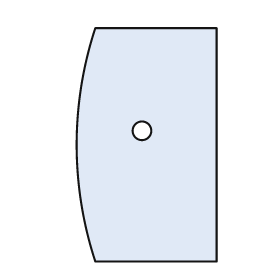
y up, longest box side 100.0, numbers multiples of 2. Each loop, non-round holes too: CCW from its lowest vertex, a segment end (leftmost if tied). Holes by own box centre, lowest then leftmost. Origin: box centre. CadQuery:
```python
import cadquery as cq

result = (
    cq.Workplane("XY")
    .moveTo(-22.0, -50.0)
    .lineTo(30.0, -50.0)
    .lineTo(30.0, 50.0)
    .lineTo(-22.0, 50.0)
    .threePointArc((-30.0, 0.0), (-22.0, -50.0))
    .close()
    .moveTo(-2.0, 6.0)
    .circle(4.0)
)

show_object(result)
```